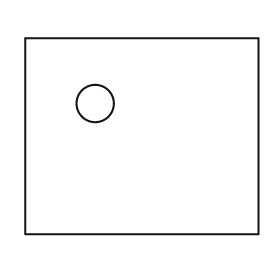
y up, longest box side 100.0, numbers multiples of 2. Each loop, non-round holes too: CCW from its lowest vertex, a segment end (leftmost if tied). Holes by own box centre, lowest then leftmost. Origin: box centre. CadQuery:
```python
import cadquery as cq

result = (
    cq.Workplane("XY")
    .moveTo(-50.0, -42.0)
    .lineTo(50.0, -42.0)
    .lineTo(50.0, 42.0)
    .lineTo(-50.0, 42.0)
    .close()
    .moveTo(-20.0, 14.0)
    .circle(8.0)
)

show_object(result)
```